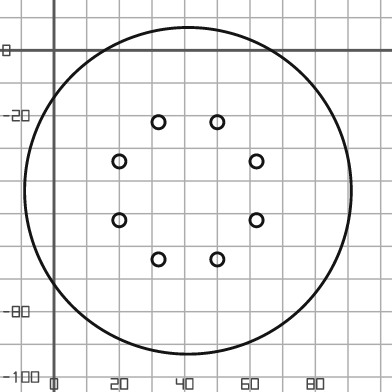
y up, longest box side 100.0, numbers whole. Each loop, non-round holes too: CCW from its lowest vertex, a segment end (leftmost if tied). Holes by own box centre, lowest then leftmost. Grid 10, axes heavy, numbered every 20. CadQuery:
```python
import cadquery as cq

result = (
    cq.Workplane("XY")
    .moveTo(41.0, -43.0)
    .circle(50.0)
    .moveTo(32.0, -64.0)
    .circle(2.0)
    .moveTo(50.0, -64.0)
    .circle(2.0)
    .moveTo(20.0, -52.0)
    .circle(2.0)
    .moveTo(62.0, -52.0)
    .circle(2.0)
    .moveTo(20.0, -34.0)
    .circle(2.0)
    .moveTo(62.0, -34.0)
    .circle(2.0)
    .moveTo(32.0, -22.0)
    .circle(2.0)
    .moveTo(50.0, -22.0)
    .circle(2.0)
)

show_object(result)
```